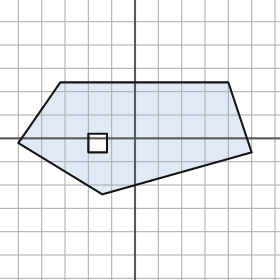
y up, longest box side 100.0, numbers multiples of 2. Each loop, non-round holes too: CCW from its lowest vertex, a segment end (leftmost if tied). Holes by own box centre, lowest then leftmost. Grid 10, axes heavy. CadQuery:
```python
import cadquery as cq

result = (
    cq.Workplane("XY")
    .moveTo(-14.0, -24.0)
    .lineTo(50.0, -6.0)
    .lineTo(40.0, 24.0)
    .lineTo(-32.0, 24.0)
    .lineTo(-50.0, -2.0)
    .close()
    .moveTo(-20.0, -6.0)
    .lineTo(-12.0, -6.0)
    .lineTo(-12.0, 2.0)
    .lineTo(-20.0, 2.0)
    .close()
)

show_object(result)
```